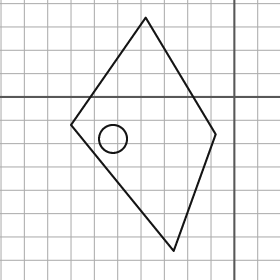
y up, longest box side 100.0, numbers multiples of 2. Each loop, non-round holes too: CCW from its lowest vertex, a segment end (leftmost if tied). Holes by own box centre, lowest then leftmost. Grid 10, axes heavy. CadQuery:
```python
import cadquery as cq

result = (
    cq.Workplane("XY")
    .moveTo(-26.0, -66.0)
    .lineTo(-8.0, -16.0)
    .lineTo(-38.0, 34.0)
    .lineTo(-70.0, -12.0)
    .close()
    .moveTo(-52.0, -18.0)
    .circle(6.0)
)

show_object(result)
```